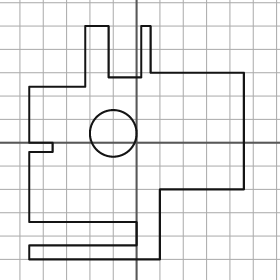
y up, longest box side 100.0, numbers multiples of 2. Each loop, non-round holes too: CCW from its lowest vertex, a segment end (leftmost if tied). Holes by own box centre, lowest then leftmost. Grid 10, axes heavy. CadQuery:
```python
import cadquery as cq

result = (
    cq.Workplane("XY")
    .moveTo(-46.0, -50.0)
    .lineTo(10.0, -50.0)
    .lineTo(10.0, -20.0)
    .lineTo(46.0, -20.0)
    .lineTo(46.0, 30.0)
    .lineTo(6.0, 30.0)
    .lineTo(6.0, 50.0)
    .lineTo(2.0, 50.0)
    .lineTo(2.0, 28.0)
    .lineTo(-12.0, 28.0)
    .lineTo(-12.0, 50.0)
    .lineTo(-22.0, 50.0)
    .lineTo(-22.0, 24.0)
    .lineTo(-46.0, 24.0)
    .lineTo(-46.0, 0.0)
    .lineTo(-36.0, 0.0)
    .lineTo(-36.0, -4.0)
    .lineTo(-46.0, -4.0)
    .lineTo(-46.0, -34.0)
    .lineTo(0.0, -34.0)
    .lineTo(0.0, -44.0)
    .lineTo(-46.0, -44.0)
    .close()
    .moveTo(-10.0, 4.0)
    .circle(10.0)
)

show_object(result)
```